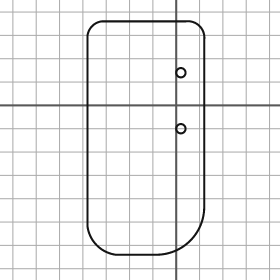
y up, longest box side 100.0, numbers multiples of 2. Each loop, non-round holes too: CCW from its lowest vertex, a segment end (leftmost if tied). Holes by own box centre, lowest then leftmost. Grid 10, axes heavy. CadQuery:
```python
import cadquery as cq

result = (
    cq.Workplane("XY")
    .moveTo(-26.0, -64.0)
    .lineTo(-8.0, -64.0)
    .threePointArc((6.0, -58.0), (12.0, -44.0))
    .lineTo(12.0, 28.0)
    .threePointArc((10.0, 34.0), (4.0, 36.0))
    .lineTo(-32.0, 36.0)
    .threePointArc((-36.0, 34.0), (-38.0, 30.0))
    .lineTo(-38.0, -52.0)
    .threePointArc((-34.0, -60.0), (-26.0, -64.0))
    .close()
    .moveTo(2.0, -10.0)
    .circle(2.0)
    .moveTo(2.0, 14.0)
    .circle(2.0)
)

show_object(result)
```